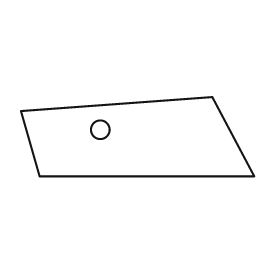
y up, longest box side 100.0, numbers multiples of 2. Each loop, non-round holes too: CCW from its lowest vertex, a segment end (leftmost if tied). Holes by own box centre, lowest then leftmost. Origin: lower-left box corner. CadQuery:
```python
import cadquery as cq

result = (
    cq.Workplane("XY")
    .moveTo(8.0, 0.0)
    .lineTo(100.0, 0.0)
    .lineTo(82.0, 34.0)
    .lineTo(0.0, 28.0)
    .close()
    .moveTo(34.0, 20.0)
    .circle(4.0)
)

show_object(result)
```